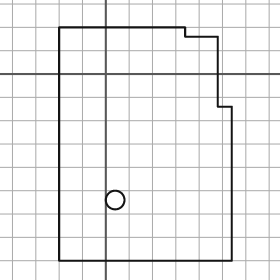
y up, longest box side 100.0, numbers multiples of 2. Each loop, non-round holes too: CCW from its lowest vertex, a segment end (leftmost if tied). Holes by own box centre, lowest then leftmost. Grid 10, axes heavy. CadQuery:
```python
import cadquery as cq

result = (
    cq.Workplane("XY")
    .moveTo(-20.0, -80.0)
    .lineTo(54.0, -80.0)
    .lineTo(54.0, -14.0)
    .lineTo(48.0, -14.0)
    .lineTo(48.0, 16.0)
    .lineTo(34.0, 16.0)
    .lineTo(34.0, 20.0)
    .lineTo(-20.0, 20.0)
    .close()
    .moveTo(4.0, -54.0)
    .circle(4.0)
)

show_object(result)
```